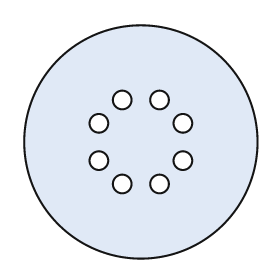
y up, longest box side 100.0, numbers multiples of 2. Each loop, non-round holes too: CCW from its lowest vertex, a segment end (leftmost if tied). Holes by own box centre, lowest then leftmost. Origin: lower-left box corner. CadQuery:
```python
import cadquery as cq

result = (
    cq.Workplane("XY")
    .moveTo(50.0, 50.0)
    .circle(50.0)
    .moveTo(42.0, 32.0)
    .circle(4.0)
    .moveTo(58.0, 32.0)
    .circle(4.0)
    .moveTo(32.0, 42.0)
    .circle(4.0)
    .moveTo(68.0, 42.0)
    .circle(4.0)
    .moveTo(32.0, 58.0)
    .circle(4.0)
    .moveTo(68.0, 58.0)
    .circle(4.0)
    .moveTo(42.0, 68.0)
    .circle(4.0)
    .moveTo(58.0, 68.0)
    .circle(4.0)
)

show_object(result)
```